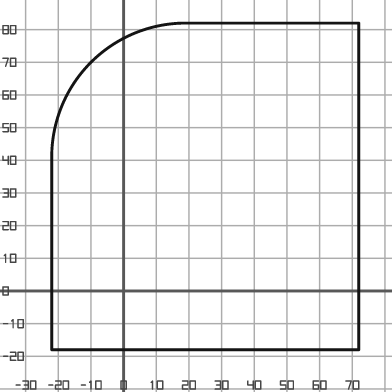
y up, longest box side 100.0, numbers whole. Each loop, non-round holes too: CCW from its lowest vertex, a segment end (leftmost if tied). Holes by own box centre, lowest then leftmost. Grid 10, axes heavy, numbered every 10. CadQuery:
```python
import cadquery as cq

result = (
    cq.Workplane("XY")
    .moveTo(-22.0, -18.0)
    .lineTo(72.0, -18.0)
    .lineTo(72.0, 82.0)
    .lineTo(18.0, 82.0)
    .threePointArc((-10.0, 70.0), (-22.0, 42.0))
    .close()
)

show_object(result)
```